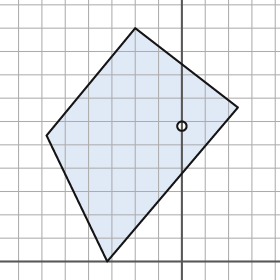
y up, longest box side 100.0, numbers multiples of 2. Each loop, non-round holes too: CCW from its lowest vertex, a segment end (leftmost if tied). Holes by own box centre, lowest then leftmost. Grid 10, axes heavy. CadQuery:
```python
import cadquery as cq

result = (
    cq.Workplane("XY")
    .moveTo(-32.0, 0.0)
    .lineTo(24.0, 66.0)
    .lineTo(-20.0, 100.0)
    .lineTo(-58.0, 54.0)
    .close()
    .moveTo(0.0, 58.0)
    .circle(2.0)
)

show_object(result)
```